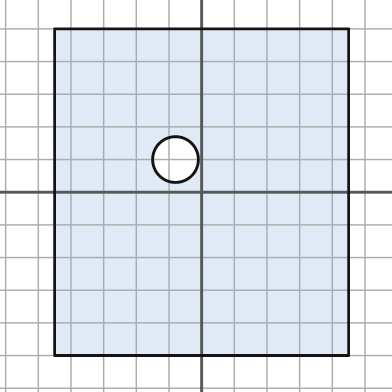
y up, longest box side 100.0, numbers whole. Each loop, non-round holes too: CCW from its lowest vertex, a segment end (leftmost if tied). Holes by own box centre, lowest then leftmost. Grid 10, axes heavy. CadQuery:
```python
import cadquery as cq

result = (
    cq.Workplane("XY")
    .moveTo(-45.0, -50.0)
    .lineTo(45.0, -50.0)
    .lineTo(45.0, 50.0)
    .lineTo(-45.0, 50.0)
    .close()
    .moveTo(-8.0, 10.0)
    .circle(7.0)
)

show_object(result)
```